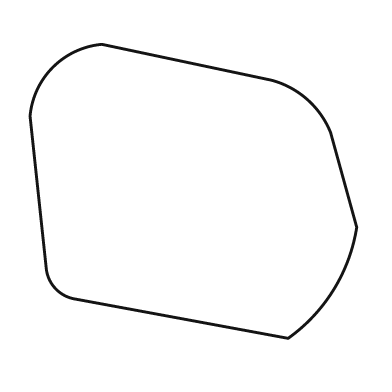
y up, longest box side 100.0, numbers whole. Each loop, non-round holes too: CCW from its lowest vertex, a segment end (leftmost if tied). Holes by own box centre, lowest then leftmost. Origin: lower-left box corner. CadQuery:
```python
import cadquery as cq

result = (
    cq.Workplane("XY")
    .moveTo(79.0, 0.0)
    .threePointArc((93.0, 15.0), (100.0, 34.0))
    .lineTo(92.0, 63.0)
    .threePointArc((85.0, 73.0), (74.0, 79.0))
    .lineTo(22.0, 90.0)
    .threePointArc((7.0, 83.0), (0.0, 68.0))
    .lineTo(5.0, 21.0)
    .threePointArc((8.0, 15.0), (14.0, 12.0))
    .close()
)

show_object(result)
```